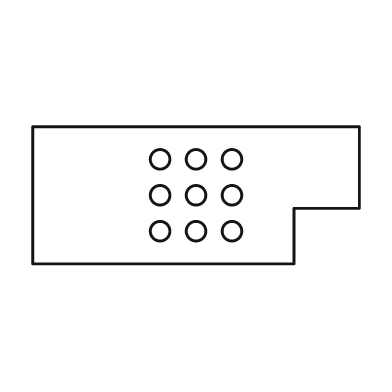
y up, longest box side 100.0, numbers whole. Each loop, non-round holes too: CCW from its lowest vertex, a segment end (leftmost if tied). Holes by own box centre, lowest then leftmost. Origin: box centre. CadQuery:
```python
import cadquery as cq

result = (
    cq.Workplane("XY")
    .moveTo(-50.0, -21.0)
    .lineTo(30.0, -21.0)
    .lineTo(30.0, -4.0)
    .lineTo(50.0, -4.0)
    .lineTo(50.0, 21.0)
    .lineTo(-50.0, 21.0)
    .close()
    .moveTo(-11.0, -11.0)
    .circle(3.0)
    .moveTo(0.0, -11.0)
    .circle(3.0)
    .moveTo(11.0, -11.0)
    .circle(3.0)
    .moveTo(-11.0, 0.0)
    .circle(3.0)
    .moveTo(0.0, 0.0)
    .circle(3.0)
    .moveTo(11.0, 0.0)
    .circle(3.0)
    .moveTo(-11.0, 11.0)
    .circle(3.0)
    .moveTo(0.0, 11.0)
    .circle(3.0)
    .moveTo(11.0, 11.0)
    .circle(3.0)
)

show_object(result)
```